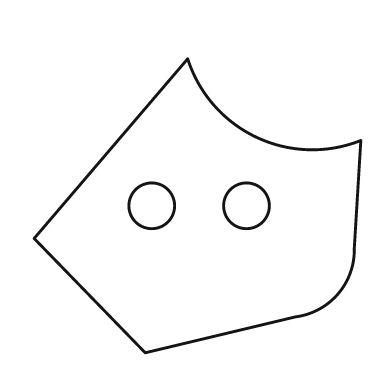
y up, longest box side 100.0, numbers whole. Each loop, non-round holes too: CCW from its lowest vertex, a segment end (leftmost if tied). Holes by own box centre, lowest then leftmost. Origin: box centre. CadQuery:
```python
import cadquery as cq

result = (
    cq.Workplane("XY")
    .moveTo(-16.0, -45.0)
    .lineTo(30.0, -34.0)
    .threePointArc((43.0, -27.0), (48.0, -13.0))
    .lineTo(50.0, 20.0)
    .threePointArc((18.0, 21.0), (-3.0, 45.0))
    .lineTo(-50.0, -10.0)
    .close()
    .moveTo(-14.0, 0.0)
    .circle(7.0)
    .moveTo(15.0, 0.0)
    .circle(7.0)
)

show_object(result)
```